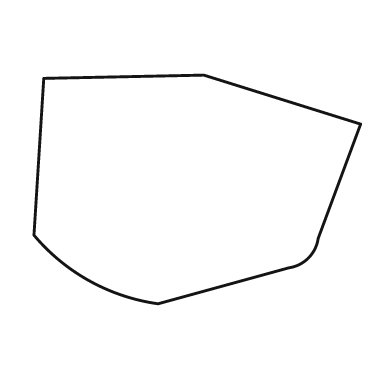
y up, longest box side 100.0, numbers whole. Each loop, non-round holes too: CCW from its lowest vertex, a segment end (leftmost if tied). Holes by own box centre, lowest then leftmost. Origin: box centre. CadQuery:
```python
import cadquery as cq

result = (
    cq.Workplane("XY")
    .moveTo(-12.0, -35.0)
    .lineTo(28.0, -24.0)
    .threePointArc((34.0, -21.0), (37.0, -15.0))
    .lineTo(50.0, 20.0)
    .lineTo(2.0, 35.0)
    .lineTo(-47.0, 34.0)
    .lineTo(-50.0, -14.0)
    .threePointArc((-33.0, -28.0), (-12.0, -35.0))
    .close()
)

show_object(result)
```